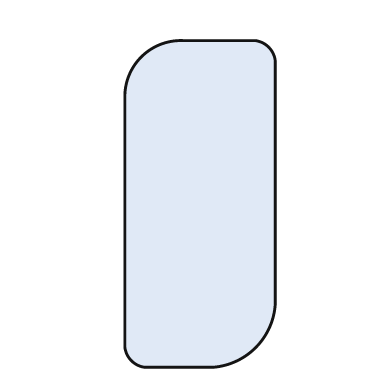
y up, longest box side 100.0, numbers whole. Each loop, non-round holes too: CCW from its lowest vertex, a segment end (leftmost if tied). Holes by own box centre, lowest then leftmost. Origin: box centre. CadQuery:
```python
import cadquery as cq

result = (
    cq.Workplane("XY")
    .moveTo(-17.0, -50.0)
    .lineTo(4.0, -50.0)
    .threePointArc((17.0, -44.0), (23.0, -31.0))
    .lineTo(23.0, 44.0)
    .threePointArc((21.0, 48.0), (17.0, 50.0))
    .lineTo(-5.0, 50.0)
    .threePointArc((-18.0, 45.0), (-23.0, 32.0))
    .lineTo(-23.0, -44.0)
    .threePointArc((-21.0, -48.0), (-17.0, -50.0))
    .close()
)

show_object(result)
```